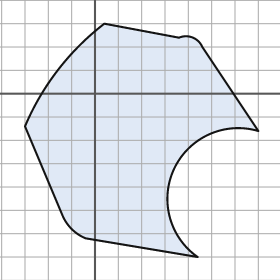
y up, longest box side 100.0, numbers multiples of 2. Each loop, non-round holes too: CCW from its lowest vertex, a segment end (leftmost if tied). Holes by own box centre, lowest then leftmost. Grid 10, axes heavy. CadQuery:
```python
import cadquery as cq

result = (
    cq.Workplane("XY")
    .moveTo(44.0, -70.0)
    .threePointArc((34.0, -32.0), (70.0, -16.0))
    .lineTo(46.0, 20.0)
    .threePointArc((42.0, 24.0), (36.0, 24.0))
    .lineTo(4.0, 30.0)
    .threePointArc((-16.0, 10.0), (-30.0, -14.0))
    .lineTo(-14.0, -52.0)
    .threePointArc((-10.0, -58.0), (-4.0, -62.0))
    .close()
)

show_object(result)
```